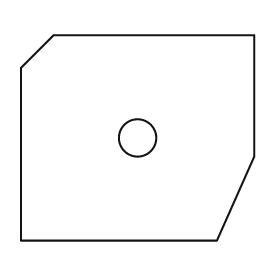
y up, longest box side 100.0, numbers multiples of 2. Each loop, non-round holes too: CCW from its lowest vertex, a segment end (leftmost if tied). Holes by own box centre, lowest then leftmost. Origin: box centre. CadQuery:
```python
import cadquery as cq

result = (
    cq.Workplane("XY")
    .moveTo(-50.0, -44.0)
    .lineTo(34.0, -44.0)
    .lineTo(50.0, -8.0)
    .lineTo(50.0, 44.0)
    .lineTo(-36.0, 44.0)
    .lineTo(-50.0, 30.0)
    .close()
    .moveTo(0.0, 0.0)
    .circle(8.0)
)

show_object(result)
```